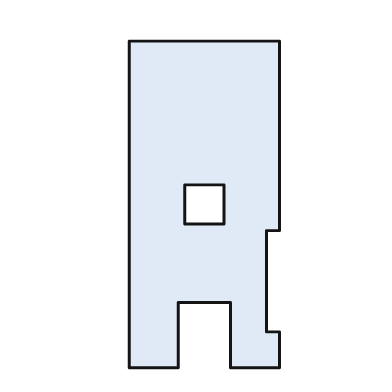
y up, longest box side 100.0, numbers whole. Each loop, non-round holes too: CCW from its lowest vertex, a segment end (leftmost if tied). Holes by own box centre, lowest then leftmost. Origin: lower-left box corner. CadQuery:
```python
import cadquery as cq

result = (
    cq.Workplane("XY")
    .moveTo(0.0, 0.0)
    .lineTo(15.0, 0.0)
    .lineTo(15.0, 20.0)
    .lineTo(31.0, 20.0)
    .lineTo(31.0, 0.0)
    .lineTo(46.0, 0.0)
    .lineTo(46.0, 11.0)
    .lineTo(42.0, 11.0)
    .lineTo(42.0, 42.0)
    .lineTo(46.0, 42.0)
    .lineTo(46.0, 100.0)
    .lineTo(0.0, 100.0)
    .close()
    .moveTo(17.0, 44.0)
    .lineTo(29.0, 44.0)
    .lineTo(29.0, 56.0)
    .lineTo(17.0, 56.0)
    .close()
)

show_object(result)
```